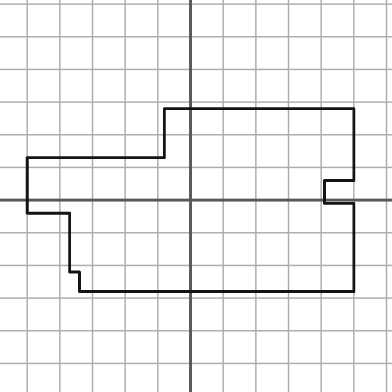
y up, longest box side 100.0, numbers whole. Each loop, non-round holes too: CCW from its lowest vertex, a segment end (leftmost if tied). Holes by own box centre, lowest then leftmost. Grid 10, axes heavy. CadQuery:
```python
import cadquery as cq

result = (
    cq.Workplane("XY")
    .moveTo(-34.0, -28.0)
    .lineTo(50.0, -28.0)
    .lineTo(50.0, -1.0)
    .lineTo(41.0, -1.0)
    .lineTo(41.0, 6.0)
    .lineTo(50.0, 6.0)
    .lineTo(50.0, 28.0)
    .lineTo(-8.0, 28.0)
    .lineTo(-8.0, 13.0)
    .lineTo(-50.0, 13.0)
    .lineTo(-50.0, -4.0)
    .lineTo(-37.0, -4.0)
    .lineTo(-37.0, -22.0)
    .lineTo(-34.0, -22.0)
    .close()
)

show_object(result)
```